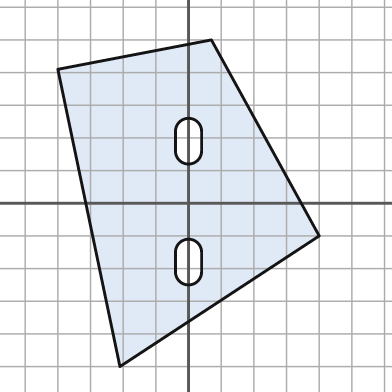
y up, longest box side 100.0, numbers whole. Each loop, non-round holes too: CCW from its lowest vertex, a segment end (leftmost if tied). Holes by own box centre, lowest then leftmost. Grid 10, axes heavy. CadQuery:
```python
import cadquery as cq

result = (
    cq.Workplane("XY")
    .moveTo(-21.0, -50.0)
    .lineTo(40.0, -10.0)
    .lineTo(7.0, 50.0)
    .lineTo(-40.0, 41.0)
    .close()
    .moveTo(-4.0, -21.0)
    .threePointArc((0.0, -25.0), (4.0, -21.0))
    .lineTo(4.0, -15.0)
    .threePointArc((0.0, -11.0), (-4.0, -15.0))
    .close()
    .moveTo(-4.0, 16.0)
    .threePointArc((0.0, 12.0), (4.0, 16.0))
    .lineTo(4.0, 22.0)
    .threePointArc((0.0, 26.0), (-4.0, 22.0))
    .close()
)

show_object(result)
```